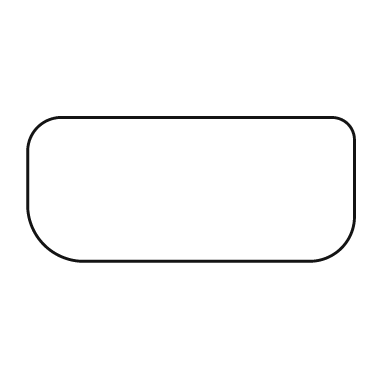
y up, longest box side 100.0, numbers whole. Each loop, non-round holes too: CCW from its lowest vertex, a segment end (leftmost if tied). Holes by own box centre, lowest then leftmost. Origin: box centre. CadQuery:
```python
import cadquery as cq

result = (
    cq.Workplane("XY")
    .moveTo(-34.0, -22.0)
    .lineTo(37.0, -22.0)
    .threePointArc((46.0, -18.0), (50.0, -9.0))
    .lineTo(50.0, 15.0)
    .threePointArc((48.0, 20.0), (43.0, 22.0))
    .lineTo(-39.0, 22.0)
    .threePointArc((-47.0, 19.0), (-50.0, 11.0))
    .lineTo(-50.0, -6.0)
    .threePointArc((-45.0, -17.0), (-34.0, -22.0))
    .close()
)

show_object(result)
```